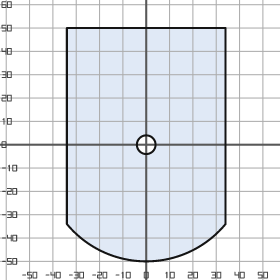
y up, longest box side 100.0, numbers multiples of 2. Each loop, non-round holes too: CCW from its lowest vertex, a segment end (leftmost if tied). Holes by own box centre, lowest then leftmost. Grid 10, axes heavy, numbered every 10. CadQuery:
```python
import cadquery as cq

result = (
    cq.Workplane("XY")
    .moveTo(-34.0, -34.0)
    .threePointArc((0.0, -50.0), (34.0, -34.0))
    .lineTo(34.0, 50.0)
    .lineTo(-34.0, 50.0)
    .close()
    .moveTo(0.0, 0.0)
    .circle(4.0)
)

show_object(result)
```